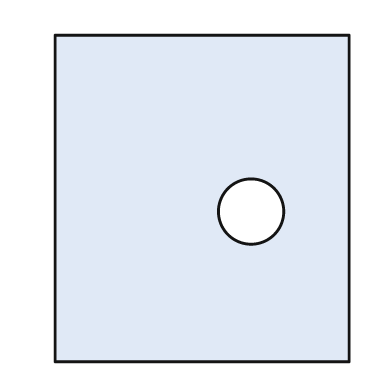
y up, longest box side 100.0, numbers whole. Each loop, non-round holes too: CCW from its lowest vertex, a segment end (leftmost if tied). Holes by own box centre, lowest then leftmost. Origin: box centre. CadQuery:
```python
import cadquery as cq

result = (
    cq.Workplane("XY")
    .moveTo(-45.0, -50.0)
    .lineTo(45.0, -50.0)
    .lineTo(45.0, 50.0)
    .lineTo(-45.0, 50.0)
    .close()
    .moveTo(15.0, -4.0)
    .circle(10.0)
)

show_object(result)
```